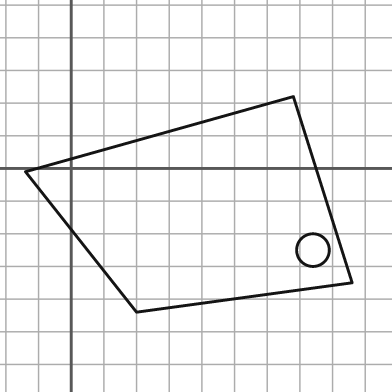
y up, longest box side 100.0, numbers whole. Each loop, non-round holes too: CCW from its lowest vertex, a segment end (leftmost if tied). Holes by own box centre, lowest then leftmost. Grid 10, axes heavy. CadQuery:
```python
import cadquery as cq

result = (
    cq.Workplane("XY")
    .moveTo(20.0, -44.0)
    .lineTo(86.0, -35.0)
    .lineTo(68.0, 22.0)
    .lineTo(-14.0, -1.0)
    .close()
    .moveTo(74.0, -25.0)
    .circle(5.0)
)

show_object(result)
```